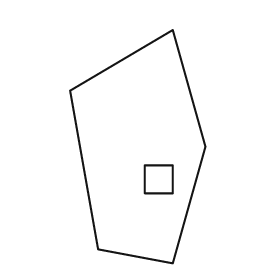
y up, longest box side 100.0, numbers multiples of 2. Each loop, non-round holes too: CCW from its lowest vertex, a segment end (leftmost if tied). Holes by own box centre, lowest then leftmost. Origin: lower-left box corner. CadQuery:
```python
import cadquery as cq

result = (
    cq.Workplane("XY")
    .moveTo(44.0, 0.0)
    .lineTo(58.0, 50.0)
    .lineTo(44.0, 100.0)
    .lineTo(0.0, 74.0)
    .lineTo(12.0, 6.0)
    .close()
    .moveTo(32.0, 30.0)
    .lineTo(44.0, 30.0)
    .lineTo(44.0, 42.0)
    .lineTo(32.0, 42.0)
    .close()
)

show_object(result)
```